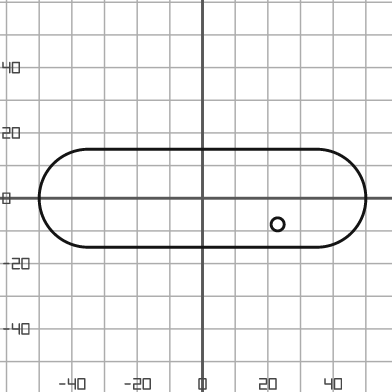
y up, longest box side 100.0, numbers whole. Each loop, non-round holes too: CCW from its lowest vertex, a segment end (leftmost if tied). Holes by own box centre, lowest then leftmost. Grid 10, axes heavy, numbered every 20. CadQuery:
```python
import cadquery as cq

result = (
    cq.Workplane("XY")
    .moveTo(-35.0, -15.0)
    .lineTo(35.0, -15.0)
    .threePointArc((50.0, 0.0), (35.0, 15.0))
    .lineTo(-35.0, 15.0)
    .threePointArc((-50.0, 0.0), (-35.0, -15.0))
    .close()
    .moveTo(23.0, -8.0)
    .circle(2.0)
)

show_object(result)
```